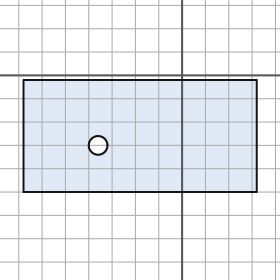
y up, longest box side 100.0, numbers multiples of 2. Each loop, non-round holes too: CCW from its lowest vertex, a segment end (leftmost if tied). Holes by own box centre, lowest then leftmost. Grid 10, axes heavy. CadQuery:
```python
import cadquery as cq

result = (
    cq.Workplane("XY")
    .moveTo(-68.0, -50.0)
    .lineTo(32.0, -50.0)
    .lineTo(32.0, -2.0)
    .lineTo(-68.0, -2.0)
    .close()
    .moveTo(-36.0, -30.0)
    .circle(4.0)
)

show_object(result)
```